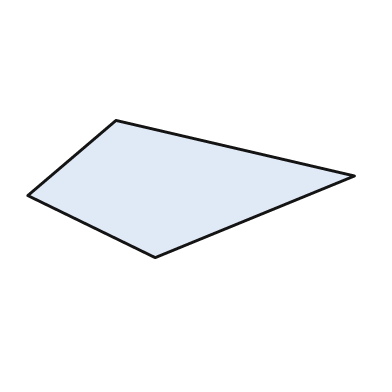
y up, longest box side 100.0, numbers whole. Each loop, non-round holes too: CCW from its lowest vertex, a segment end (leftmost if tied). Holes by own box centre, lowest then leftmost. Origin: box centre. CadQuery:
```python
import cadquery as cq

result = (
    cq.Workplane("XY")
    .moveTo(-11.0, -21.0)
    .lineTo(50.0, 4.0)
    .lineTo(-23.0, 21.0)
    .lineTo(-50.0, -2.0)
    .close()
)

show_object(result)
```